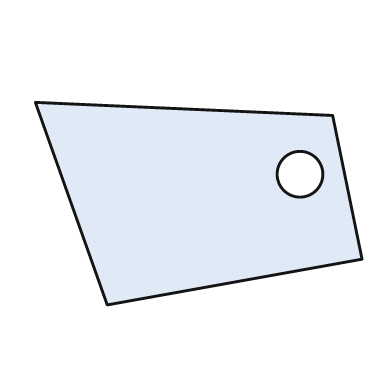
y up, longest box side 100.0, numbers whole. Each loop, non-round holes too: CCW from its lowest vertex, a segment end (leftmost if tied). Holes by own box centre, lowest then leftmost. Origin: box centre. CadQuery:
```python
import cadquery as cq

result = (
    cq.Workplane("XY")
    .moveTo(-28.0, -31.0)
    .lineTo(50.0, -17.0)
    .lineTo(41.0, 27.0)
    .lineTo(-50.0, 31.0)
    .close()
    .moveTo(31.0, 9.0)
    .circle(7.0)
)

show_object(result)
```